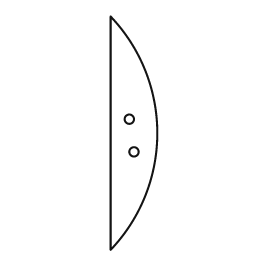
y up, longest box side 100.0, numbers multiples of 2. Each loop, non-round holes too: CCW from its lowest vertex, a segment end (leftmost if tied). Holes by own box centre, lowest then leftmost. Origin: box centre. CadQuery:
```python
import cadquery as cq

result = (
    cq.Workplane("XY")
    .moveTo(-10.0, -50.0)
    .threePointArc((10.0, 0.0), (-10.0, 50.0))
    .close()
    .moveTo(0.0, -8.0)
    .circle(2.0)
    .moveTo(-2.0, 6.0)
    .circle(2.0)
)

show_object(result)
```